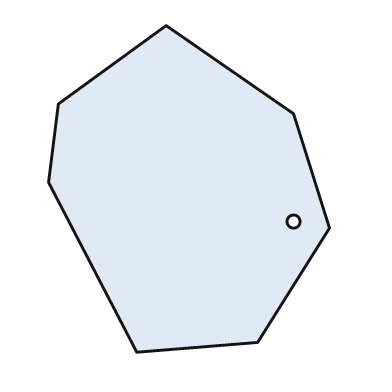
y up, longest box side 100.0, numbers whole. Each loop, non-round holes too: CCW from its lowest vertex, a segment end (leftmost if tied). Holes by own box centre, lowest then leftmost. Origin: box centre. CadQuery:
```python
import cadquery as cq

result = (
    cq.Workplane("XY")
    .moveTo(-16.0, -50.0)
    .lineTo(21.0, -47.0)
    .lineTo(43.0, -12.0)
    .lineTo(32.0, 23.0)
    .lineTo(-7.0, 50.0)
    .lineTo(-40.0, 26.0)
    .lineTo(-43.0, 2.0)
    .close()
    .moveTo(32.0, -10.0)
    .circle(2.0)
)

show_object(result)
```